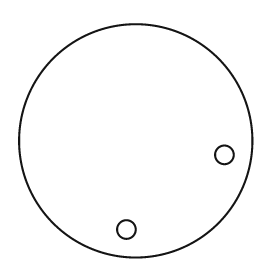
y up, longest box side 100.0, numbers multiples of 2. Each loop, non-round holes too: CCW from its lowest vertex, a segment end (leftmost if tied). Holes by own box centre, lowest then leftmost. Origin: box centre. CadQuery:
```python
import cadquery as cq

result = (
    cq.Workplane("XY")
    .moveTo(0.0, 0.0)
    .circle(50.0)
    .moveTo(-4.0, -38.0)
    .circle(4.0)
    .moveTo(38.0, -6.0)
    .circle(4.0)
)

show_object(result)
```